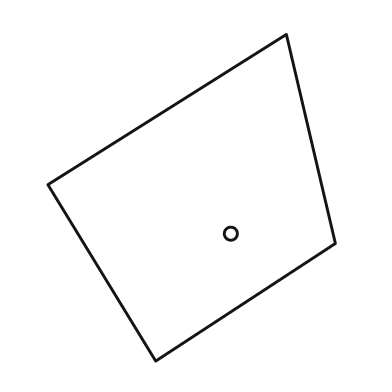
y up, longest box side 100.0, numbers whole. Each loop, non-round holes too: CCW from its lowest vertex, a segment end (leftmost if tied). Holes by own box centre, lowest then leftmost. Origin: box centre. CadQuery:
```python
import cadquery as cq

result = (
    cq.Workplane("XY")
    .moveTo(-11.0, -50.0)
    .lineTo(44.0, -14.0)
    .lineTo(29.0, 50.0)
    .lineTo(-44.0, 4.0)
    .close()
    .moveTo(12.0, -11.0)
    .circle(2.0)
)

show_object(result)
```